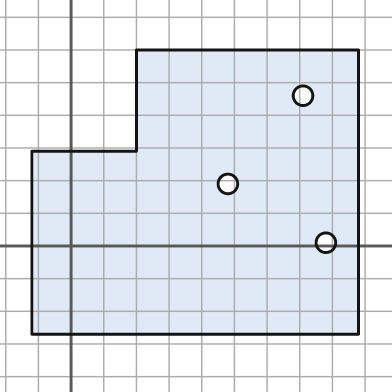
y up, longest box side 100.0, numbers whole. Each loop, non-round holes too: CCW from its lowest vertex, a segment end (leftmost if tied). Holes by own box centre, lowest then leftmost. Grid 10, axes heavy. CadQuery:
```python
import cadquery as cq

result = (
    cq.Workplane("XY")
    .moveTo(-12.0, -27.0)
    .lineTo(88.0, -27.0)
    .lineTo(88.0, 60.0)
    .lineTo(20.0, 60.0)
    .lineTo(20.0, 29.0)
    .lineTo(-12.0, 29.0)
    .close()
    .moveTo(78.0, 1.0)
    .circle(3.0)
    .moveTo(48.0, 19.0)
    .circle(3.0)
    .moveTo(71.0, 46.0)
    .circle(3.0)
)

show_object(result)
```